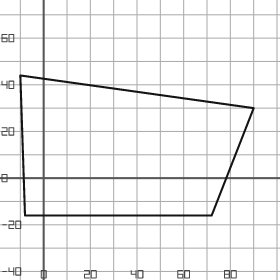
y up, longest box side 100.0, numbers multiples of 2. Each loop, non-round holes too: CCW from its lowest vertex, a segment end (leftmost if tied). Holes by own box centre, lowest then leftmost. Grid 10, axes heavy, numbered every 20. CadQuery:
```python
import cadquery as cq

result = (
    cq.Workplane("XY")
    .moveTo(-8.0, -16.0)
    .lineTo(72.0, -16.0)
    .lineTo(90.0, 30.0)
    .lineTo(-10.0, 44.0)
    .close()
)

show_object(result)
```